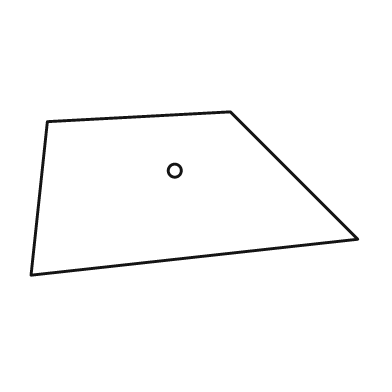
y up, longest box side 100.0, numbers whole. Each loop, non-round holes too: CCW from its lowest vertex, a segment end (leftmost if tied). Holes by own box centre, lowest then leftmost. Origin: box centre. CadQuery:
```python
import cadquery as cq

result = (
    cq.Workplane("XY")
    .moveTo(-50.0, -25.0)
    .lineTo(50.0, -14.0)
    .lineTo(11.0, 25.0)
    .lineTo(-45.0, 22.0)
    .close()
    .moveTo(-6.0, 7.0)
    .circle(2.0)
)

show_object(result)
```